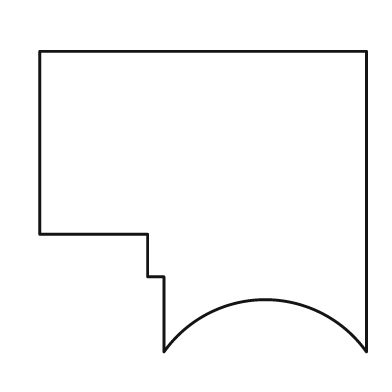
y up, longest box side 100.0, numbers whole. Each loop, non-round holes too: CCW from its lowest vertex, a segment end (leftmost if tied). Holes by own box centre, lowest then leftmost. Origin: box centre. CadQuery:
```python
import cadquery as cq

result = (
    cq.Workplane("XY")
    .moveTo(-12.0, -46.0)
    .threePointArc((19.0, -30.0), (50.0, -46.0))
    .lineTo(50.0, 46.0)
    .lineTo(-50.0, 46.0)
    .lineTo(-50.0, -10.0)
    .lineTo(-17.0, -10.0)
    .lineTo(-17.0, -23.0)
    .lineTo(-12.0, -23.0)
    .close()
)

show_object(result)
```